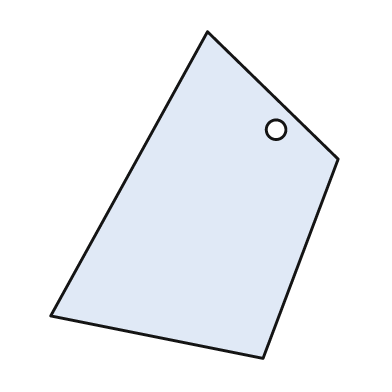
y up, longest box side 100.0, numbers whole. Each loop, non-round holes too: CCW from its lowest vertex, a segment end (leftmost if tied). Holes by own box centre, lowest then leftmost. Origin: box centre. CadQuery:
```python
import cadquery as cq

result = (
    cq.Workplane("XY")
    .moveTo(21.0, -50.0)
    .lineTo(44.0, 11.0)
    .lineTo(4.0, 50.0)
    .lineTo(-44.0, -37.0)
    .close()
    .moveTo(25.0, 20.0)
    .circle(3.0)
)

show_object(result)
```